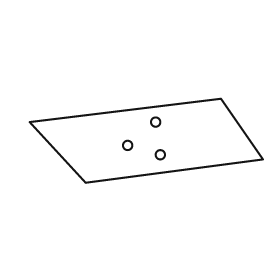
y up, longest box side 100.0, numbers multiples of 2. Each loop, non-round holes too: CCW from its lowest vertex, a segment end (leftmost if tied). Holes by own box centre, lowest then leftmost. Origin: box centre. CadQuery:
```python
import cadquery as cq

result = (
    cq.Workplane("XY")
    .moveTo(-26.0, -18.0)
    .lineTo(50.0, -8.0)
    .lineTo(32.0, 18.0)
    .lineTo(-50.0, 8.0)
    .close()
    .moveTo(6.0, -6.0)
    .circle(2.0)
    .moveTo(-8.0, -2.0)
    .circle(2.0)
    .moveTo(4.0, 8.0)
    .circle(2.0)
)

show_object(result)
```